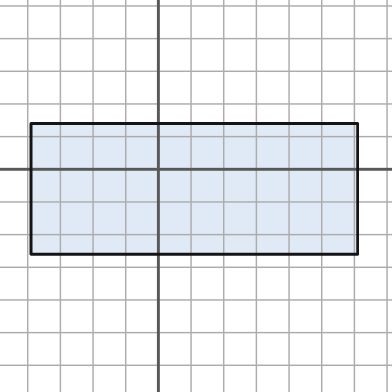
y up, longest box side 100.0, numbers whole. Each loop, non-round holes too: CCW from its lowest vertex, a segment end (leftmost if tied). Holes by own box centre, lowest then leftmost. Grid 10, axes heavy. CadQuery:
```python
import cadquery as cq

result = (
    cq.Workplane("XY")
    .moveTo(-39.0, -26.0)
    .lineTo(61.0, -26.0)
    .lineTo(61.0, 14.0)
    .lineTo(-39.0, 14.0)
    .close()
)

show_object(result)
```